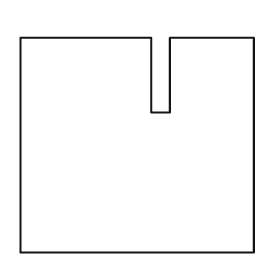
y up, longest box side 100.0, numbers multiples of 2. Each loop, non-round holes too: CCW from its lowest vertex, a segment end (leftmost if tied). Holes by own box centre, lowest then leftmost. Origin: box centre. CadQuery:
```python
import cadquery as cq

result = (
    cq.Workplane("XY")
    .moveTo(-50.0, -46.0)
    .lineTo(50.0, -46.0)
    .lineTo(50.0, 46.0)
    .lineTo(14.0, 46.0)
    .lineTo(14.0, 14.0)
    .lineTo(6.0, 14.0)
    .lineTo(6.0, 46.0)
    .lineTo(-50.0, 46.0)
    .close()
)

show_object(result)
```